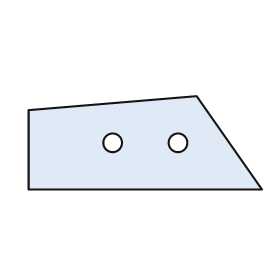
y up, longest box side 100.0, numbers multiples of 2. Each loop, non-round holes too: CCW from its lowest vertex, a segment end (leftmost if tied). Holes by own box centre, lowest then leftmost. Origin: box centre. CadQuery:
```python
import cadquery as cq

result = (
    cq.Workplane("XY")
    .moveTo(-50.0, -20.0)
    .lineTo(50.0, -20.0)
    .lineTo(22.0, 20.0)
    .lineTo(-50.0, 14.0)
    .close()
    .moveTo(-14.0, 0.0)
    .circle(4.0)
    .moveTo(14.0, 0.0)
    .circle(4.0)
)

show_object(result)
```